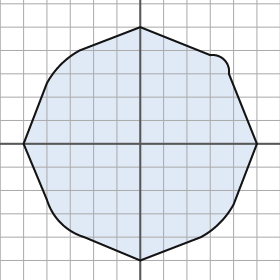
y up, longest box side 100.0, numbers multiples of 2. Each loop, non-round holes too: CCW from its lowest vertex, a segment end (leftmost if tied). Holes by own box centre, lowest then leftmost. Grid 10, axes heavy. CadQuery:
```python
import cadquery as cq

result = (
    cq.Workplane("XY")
    .moveTo(0.0, -50.0)
    .lineTo(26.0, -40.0)
    .threePointArc((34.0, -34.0), (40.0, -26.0))
    .lineTo(50.0, 0.0)
    .lineTo(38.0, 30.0)
    .threePointArc((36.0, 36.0), (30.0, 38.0))
    .lineTo(0.0, 50.0)
    .lineTo(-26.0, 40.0)
    .threePointArc((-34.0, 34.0), (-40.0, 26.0))
    .lineTo(-50.0, 0.0)
    .lineTo(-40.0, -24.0)
    .threePointArc((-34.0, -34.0), (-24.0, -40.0))
    .close()
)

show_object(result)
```